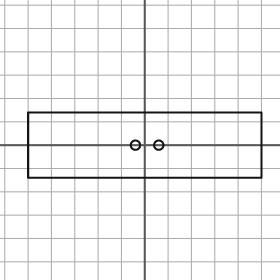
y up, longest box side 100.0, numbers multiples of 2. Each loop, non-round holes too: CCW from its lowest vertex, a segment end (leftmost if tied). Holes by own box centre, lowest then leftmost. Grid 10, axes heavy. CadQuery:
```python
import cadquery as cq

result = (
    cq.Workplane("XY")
    .moveTo(-50.0, -14.0)
    .lineTo(50.0, -14.0)
    .lineTo(50.0, 14.0)
    .lineTo(-50.0, 14.0)
    .close()
    .moveTo(-4.0, 0.0)
    .circle(2.0)
    .moveTo(6.0, 0.0)
    .circle(2.0)
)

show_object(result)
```